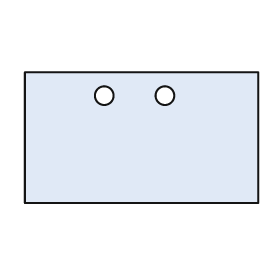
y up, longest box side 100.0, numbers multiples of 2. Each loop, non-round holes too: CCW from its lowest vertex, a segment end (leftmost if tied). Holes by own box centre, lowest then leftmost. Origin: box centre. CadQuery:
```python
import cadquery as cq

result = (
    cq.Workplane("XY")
    .moveTo(-50.0, -28.0)
    .lineTo(50.0, -28.0)
    .lineTo(50.0, 28.0)
    .lineTo(-50.0, 28.0)
    .close()
    .moveTo(-16.0, 18.0)
    .circle(4.0)
    .moveTo(10.0, 18.0)
    .circle(4.0)
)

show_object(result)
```